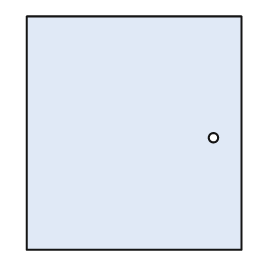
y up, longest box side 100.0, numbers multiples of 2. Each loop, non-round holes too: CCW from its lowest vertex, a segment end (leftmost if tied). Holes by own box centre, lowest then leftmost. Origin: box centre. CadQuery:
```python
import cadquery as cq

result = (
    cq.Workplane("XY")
    .moveTo(-46.0, -50.0)
    .lineTo(46.0, -50.0)
    .lineTo(46.0, 50.0)
    .lineTo(-46.0, 50.0)
    .close()
    .moveTo(34.0, -2.0)
    .circle(2.0)
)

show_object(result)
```